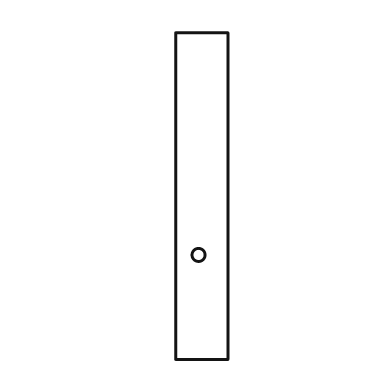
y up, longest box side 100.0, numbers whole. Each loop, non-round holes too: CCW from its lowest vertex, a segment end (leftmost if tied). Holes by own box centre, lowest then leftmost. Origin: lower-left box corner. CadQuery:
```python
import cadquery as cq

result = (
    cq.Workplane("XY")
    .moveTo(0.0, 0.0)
    .lineTo(16.0, 0.0)
    .lineTo(16.0, 100.0)
    .lineTo(0.0, 100.0)
    .close()
    .moveTo(7.0, 32.0)
    .circle(2.0)
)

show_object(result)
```